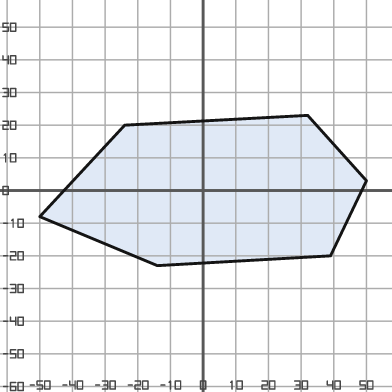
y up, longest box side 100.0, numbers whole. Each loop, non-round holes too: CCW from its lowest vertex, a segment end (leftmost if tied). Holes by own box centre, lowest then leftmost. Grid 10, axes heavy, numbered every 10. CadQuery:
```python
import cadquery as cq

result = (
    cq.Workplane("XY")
    .moveTo(-14.0, -23.0)
    .lineTo(39.0, -20.0)
    .lineTo(50.0, 3.0)
    .lineTo(32.0, 23.0)
    .lineTo(-24.0, 20.0)
    .lineTo(-50.0, -8.0)
    .close()
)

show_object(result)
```